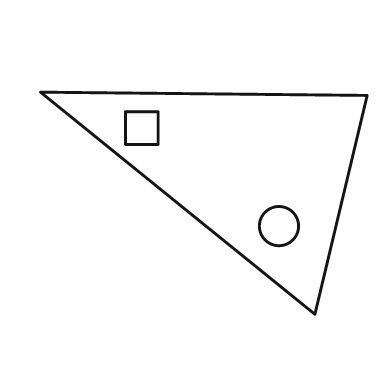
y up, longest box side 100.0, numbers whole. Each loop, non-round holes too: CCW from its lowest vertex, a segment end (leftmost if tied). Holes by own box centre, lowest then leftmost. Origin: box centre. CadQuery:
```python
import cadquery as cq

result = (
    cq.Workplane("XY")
    .moveTo(34.0, -34.0)
    .lineTo(50.0, 33.0)
    .lineTo(-50.0, 34.0)
    .close()
    .moveTo(23.0, -7.0)
    .circle(6.0)
    .moveTo(-24.0, 18.0)
    .lineTo(-14.0, 18.0)
    .lineTo(-14.0, 28.0)
    .lineTo(-24.0, 28.0)
    .close()
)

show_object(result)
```